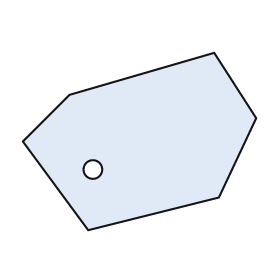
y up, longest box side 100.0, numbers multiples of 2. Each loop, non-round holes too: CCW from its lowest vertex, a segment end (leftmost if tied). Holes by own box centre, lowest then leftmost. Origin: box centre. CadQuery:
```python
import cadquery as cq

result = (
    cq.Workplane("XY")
    .moveTo(-22.0, -38.0)
    .lineTo(34.0, -24.0)
    .lineTo(50.0, 10.0)
    .lineTo(32.0, 38.0)
    .lineTo(-30.0, 20.0)
    .lineTo(-50.0, 0.0)
    .close()
    .moveTo(-20.0, -12.0)
    .circle(4.0)
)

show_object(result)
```